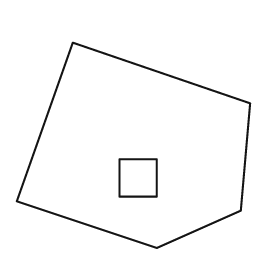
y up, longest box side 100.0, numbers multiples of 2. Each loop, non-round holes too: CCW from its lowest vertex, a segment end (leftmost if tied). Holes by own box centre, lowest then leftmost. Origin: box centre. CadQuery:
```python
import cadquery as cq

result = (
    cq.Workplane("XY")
    .moveTo(10.0, -44.0)
    .lineTo(46.0, -28.0)
    .lineTo(50.0, 18.0)
    .lineTo(-26.0, 44.0)
    .lineTo(-50.0, -24.0)
    .close()
    .moveTo(-6.0, -22.0)
    .lineTo(10.0, -22.0)
    .lineTo(10.0, -6.0)
    .lineTo(-6.0, -6.0)
    .close()
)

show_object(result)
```